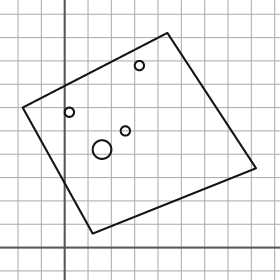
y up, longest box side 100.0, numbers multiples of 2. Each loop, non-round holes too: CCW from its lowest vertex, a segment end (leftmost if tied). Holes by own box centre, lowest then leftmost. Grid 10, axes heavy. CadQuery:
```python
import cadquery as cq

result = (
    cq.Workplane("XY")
    .moveTo(12.0, 6.0)
    .lineTo(82.0, 34.0)
    .lineTo(44.0, 92.0)
    .lineTo(-18.0, 60.0)
    .close()
    .moveTo(16.0, 42.0)
    .circle(4.0)
    .moveTo(26.0, 50.0)
    .circle(2.0)
    .moveTo(2.0, 58.0)
    .circle(2.0)
    .moveTo(32.0, 78.0)
    .circle(2.0)
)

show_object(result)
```